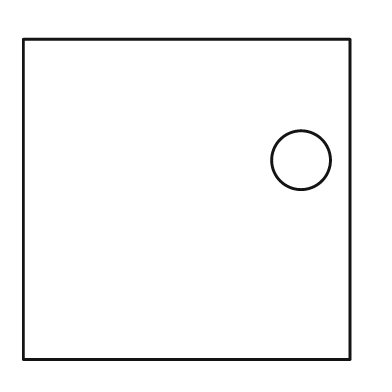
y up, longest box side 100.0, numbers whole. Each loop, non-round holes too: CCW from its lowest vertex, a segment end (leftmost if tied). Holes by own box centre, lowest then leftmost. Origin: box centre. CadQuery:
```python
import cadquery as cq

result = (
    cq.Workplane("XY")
    .moveTo(-50.0, -49.0)
    .lineTo(50.0, -49.0)
    .lineTo(50.0, 49.0)
    .lineTo(-50.0, 49.0)
    .close()
    .moveTo(35.0, 12.0)
    .circle(9.0)
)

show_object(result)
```